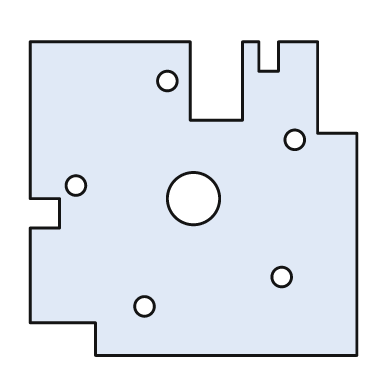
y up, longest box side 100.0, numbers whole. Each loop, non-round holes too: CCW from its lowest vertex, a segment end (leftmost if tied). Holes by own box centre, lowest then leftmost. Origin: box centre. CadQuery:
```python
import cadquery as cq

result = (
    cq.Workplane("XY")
    .moveTo(-30.0, -48.0)
    .lineTo(50.0, -48.0)
    .lineTo(50.0, 20.0)
    .lineTo(38.0, 20.0)
    .lineTo(38.0, 48.0)
    .lineTo(26.0, 48.0)
    .lineTo(26.0, 39.0)
    .lineTo(20.0, 39.0)
    .lineTo(20.0, 48.0)
    .lineTo(15.0, 48.0)
    .lineTo(15.0, 24.0)
    .lineTo(-1.0, 24.0)
    .lineTo(-1.0, 48.0)
    .lineTo(-50.0, 48.0)
    .lineTo(-50.0, 0.0)
    .lineTo(-41.0, 0.0)
    .lineTo(-41.0, -9.0)
    .lineTo(-50.0, -9.0)
    .lineTo(-50.0, -38.0)
    .lineTo(-30.0, -38.0)
    .close()
    .moveTo(-15.0, -33.0)
    .circle(3.0)
    .moveTo(27.0, -24.0)
    .circle(3.0)
    .moveTo(0.0, 0.0)
    .circle(8.0)
    .moveTo(-36.0, 4.0)
    .circle(3.0)
    .moveTo(31.0, 18.0)
    .circle(3.0)
    .moveTo(-8.0, 36.0)
    .circle(3.0)
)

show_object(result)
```